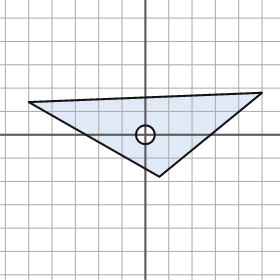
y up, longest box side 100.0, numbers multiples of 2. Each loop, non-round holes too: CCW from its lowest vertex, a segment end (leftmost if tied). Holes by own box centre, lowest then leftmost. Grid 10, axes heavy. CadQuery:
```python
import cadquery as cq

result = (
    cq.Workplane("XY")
    .moveTo(6.0, -18.0)
    .lineTo(50.0, 18.0)
    .lineTo(-50.0, 14.0)
    .close()
    .moveTo(0.0, 0.0)
    .circle(4.0)
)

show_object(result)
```